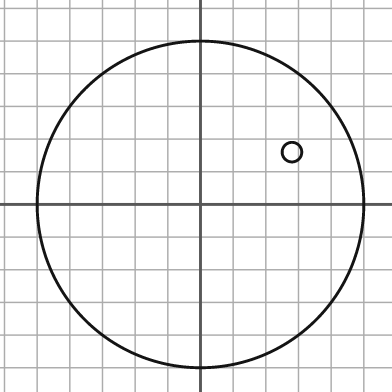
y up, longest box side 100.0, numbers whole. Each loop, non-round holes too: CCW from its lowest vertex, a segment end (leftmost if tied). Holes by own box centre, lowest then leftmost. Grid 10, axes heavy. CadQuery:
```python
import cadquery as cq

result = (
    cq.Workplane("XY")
    .moveTo(0.0, 0.0)
    .circle(50.0)
    .moveTo(28.0, 16.0)
    .circle(3.0)
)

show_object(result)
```